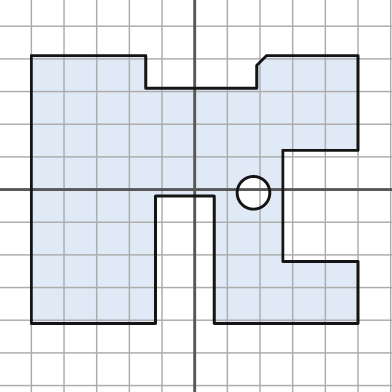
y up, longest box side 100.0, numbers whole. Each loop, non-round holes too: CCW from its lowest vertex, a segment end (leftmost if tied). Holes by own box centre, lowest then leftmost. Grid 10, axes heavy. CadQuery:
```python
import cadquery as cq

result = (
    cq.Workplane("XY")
    .moveTo(-50.0, -41.0)
    .lineTo(-12.0, -41.0)
    .lineTo(-12.0, -2.0)
    .lineTo(6.0, -2.0)
    .lineTo(6.0, -41.0)
    .lineTo(50.0, -41.0)
    .lineTo(50.0, -22.0)
    .lineTo(27.0, -22.0)
    .lineTo(27.0, 12.0)
    .lineTo(50.0, 12.0)
    .lineTo(50.0, 41.0)
    .lineTo(22.0, 41.0)
    .lineTo(19.0, 38.0)
    .lineTo(19.0, 31.0)
    .lineTo(-15.0, 31.0)
    .lineTo(-15.0, 41.0)
    .lineTo(-50.0, 41.0)
    .close()
    .moveTo(18.0, -1.0)
    .circle(5.0)
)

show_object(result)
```